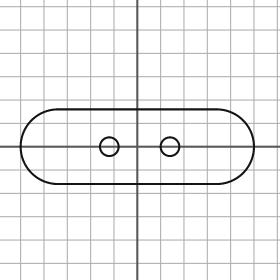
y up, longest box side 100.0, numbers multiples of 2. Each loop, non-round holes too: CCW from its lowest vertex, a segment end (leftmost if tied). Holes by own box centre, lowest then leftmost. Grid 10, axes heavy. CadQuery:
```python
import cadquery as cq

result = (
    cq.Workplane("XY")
    .moveTo(-34.0, -16.0)
    .lineTo(34.0, -16.0)
    .threePointArc((50.0, 0.0), (34.0, 16.0))
    .lineTo(-34.0, 16.0)
    .threePointArc((-50.0, 0.0), (-34.0, -16.0))
    .close()
    .moveTo(-12.0, 0.0)
    .circle(4.0)
    .moveTo(14.0, 0.0)
    .circle(4.0)
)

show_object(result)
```